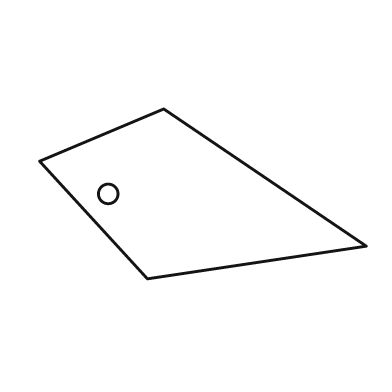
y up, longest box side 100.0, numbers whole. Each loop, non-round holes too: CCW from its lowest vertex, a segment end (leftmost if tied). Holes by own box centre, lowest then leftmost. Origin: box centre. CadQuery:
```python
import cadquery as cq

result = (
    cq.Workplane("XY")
    .moveTo(-17.0, -26.0)
    .lineTo(50.0, -16.0)
    .lineTo(-12.0, 26.0)
    .lineTo(-50.0, 10.0)
    .close()
    .moveTo(-29.0, 0.0)
    .circle(3.0)
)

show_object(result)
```